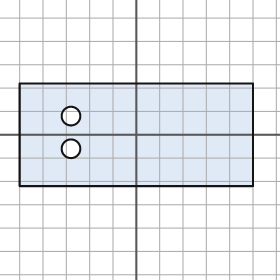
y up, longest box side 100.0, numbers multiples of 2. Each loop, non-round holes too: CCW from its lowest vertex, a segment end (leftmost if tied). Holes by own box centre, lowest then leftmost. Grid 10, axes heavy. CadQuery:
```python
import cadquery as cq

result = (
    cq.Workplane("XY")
    .moveTo(-50.0, -22.0)
    .lineTo(50.0, -22.0)
    .lineTo(50.0, 22.0)
    .lineTo(-50.0, 22.0)
    .close()
    .moveTo(-28.0, -6.0)
    .circle(4.0)
    .moveTo(-28.0, 8.0)
    .circle(4.0)
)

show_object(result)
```